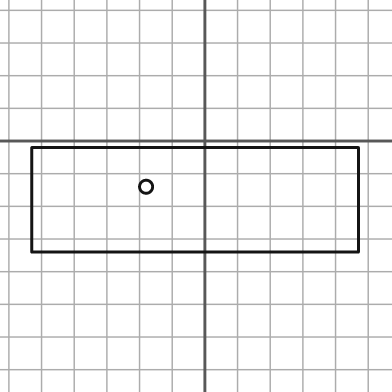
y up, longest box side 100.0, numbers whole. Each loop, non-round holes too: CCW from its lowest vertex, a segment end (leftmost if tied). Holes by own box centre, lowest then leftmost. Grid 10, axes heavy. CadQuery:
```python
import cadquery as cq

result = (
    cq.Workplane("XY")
    .moveTo(-53.0, -34.0)
    .lineTo(47.0, -34.0)
    .lineTo(47.0, -2.0)
    .lineTo(-53.0, -2.0)
    .close()
    .moveTo(-18.0, -14.0)
    .circle(2.0)
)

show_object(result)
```